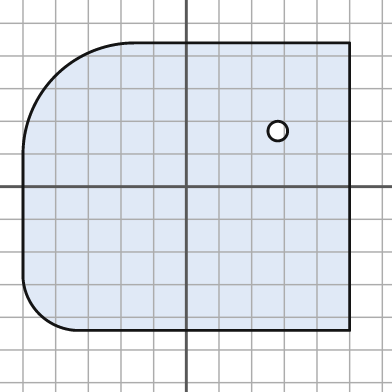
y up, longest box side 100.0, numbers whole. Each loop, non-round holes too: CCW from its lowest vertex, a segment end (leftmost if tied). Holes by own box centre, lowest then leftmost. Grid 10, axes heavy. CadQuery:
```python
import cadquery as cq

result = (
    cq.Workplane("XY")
    .moveTo(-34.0, -44.0)
    .lineTo(50.0, -44.0)
    .lineTo(50.0, 44.0)
    .lineTo(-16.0, 44.0)
    .threePointArc((-40.0, 34.0), (-50.0, 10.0))
    .lineTo(-50.0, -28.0)
    .threePointArc((-45.0, -39.0), (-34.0, -44.0))
    .close()
    .moveTo(28.0, 17.0)
    .circle(3.0)
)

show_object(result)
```